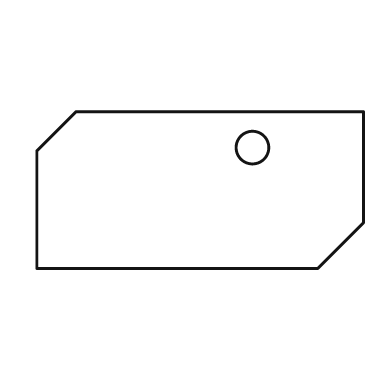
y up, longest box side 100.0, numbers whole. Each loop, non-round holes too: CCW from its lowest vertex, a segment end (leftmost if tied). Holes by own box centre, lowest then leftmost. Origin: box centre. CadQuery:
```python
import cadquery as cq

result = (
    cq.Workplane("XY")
    .moveTo(-50.0, -24.0)
    .lineTo(36.0, -24.0)
    .lineTo(50.0, -10.0)
    .lineTo(50.0, 24.0)
    .lineTo(-38.0, 24.0)
    .lineTo(-50.0, 12.0)
    .close()
    .moveTo(16.0, 13.0)
    .circle(5.0)
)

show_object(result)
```